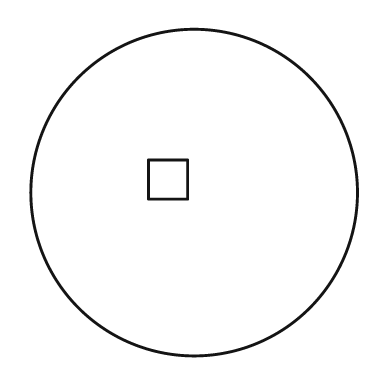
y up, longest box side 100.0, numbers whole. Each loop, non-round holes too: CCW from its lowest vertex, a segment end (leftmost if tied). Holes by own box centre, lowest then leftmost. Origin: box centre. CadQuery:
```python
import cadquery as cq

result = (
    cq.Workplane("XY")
    .moveTo(0.0, 0.0)
    .circle(50.0)
    .moveTo(-14.0, -2.0)
    .lineTo(-2.0, -2.0)
    .lineTo(-2.0, 10.0)
    .lineTo(-14.0, 10.0)
    .close()
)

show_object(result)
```